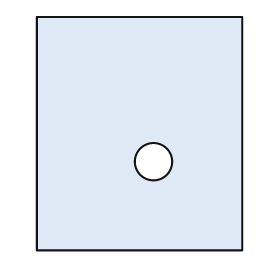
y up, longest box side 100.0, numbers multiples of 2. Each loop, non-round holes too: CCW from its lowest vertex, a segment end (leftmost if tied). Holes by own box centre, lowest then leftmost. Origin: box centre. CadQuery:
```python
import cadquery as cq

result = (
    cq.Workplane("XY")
    .moveTo(-44.0, -50.0)
    .lineTo(44.0, -50.0)
    .lineTo(44.0, 50.0)
    .lineTo(-44.0, 50.0)
    .close()
    .moveTo(6.0, -12.0)
    .circle(8.0)
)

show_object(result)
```